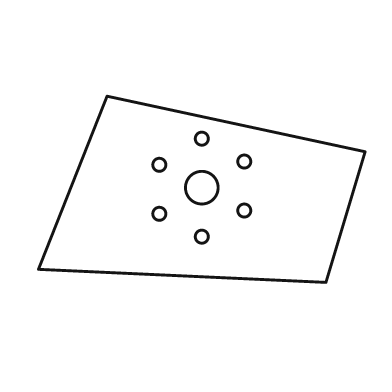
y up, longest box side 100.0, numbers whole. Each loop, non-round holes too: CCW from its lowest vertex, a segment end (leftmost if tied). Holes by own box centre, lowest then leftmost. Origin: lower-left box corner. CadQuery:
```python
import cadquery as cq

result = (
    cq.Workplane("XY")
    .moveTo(88.0, 0.0)
    .lineTo(100.0, 40.0)
    .lineTo(21.0, 57.0)
    .lineTo(0.0, 4.0)
    .close()
    .moveTo(50.0, 14.0)
    .circle(2.0)
    .moveTo(37.0, 21.0)
    .circle(2.0)
    .moveTo(63.0, 22.0)
    .circle(2.0)
    .moveTo(50.0, 29.0)
    .circle(5.0)
    .moveTo(37.0, 36.0)
    .circle(2.0)
    .moveTo(63.0, 37.0)
    .circle(2.0)
    .moveTo(50.0, 44.0)
    .circle(2.0)
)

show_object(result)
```